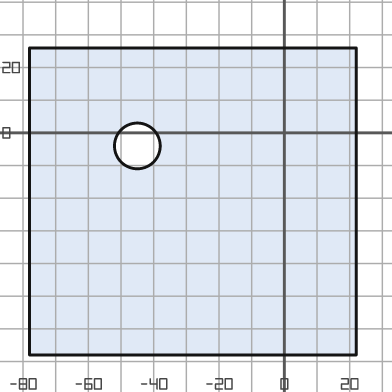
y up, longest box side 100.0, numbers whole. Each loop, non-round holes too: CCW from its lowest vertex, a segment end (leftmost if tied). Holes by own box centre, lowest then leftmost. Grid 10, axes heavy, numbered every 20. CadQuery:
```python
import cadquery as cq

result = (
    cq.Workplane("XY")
    .moveTo(-78.0, -68.0)
    .lineTo(22.0, -68.0)
    .lineTo(22.0, 26.0)
    .lineTo(-78.0, 26.0)
    .close()
    .moveTo(-45.0, -4.0)
    .circle(7.0)
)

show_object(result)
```